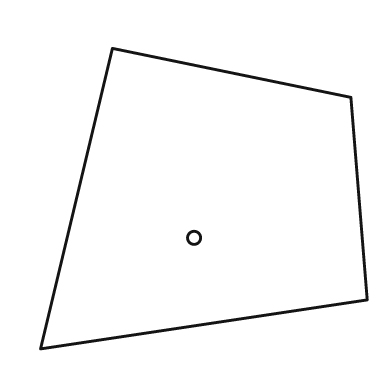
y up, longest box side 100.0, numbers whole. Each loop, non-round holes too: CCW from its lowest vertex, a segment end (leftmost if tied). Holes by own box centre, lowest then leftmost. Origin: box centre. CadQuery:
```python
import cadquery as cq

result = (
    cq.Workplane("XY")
    .moveTo(-50.0, -46.0)
    .lineTo(50.0, -31.0)
    .lineTo(45.0, 31.0)
    .lineTo(-28.0, 46.0)
    .close()
    .moveTo(-3.0, -12.0)
    .circle(2.0)
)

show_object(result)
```